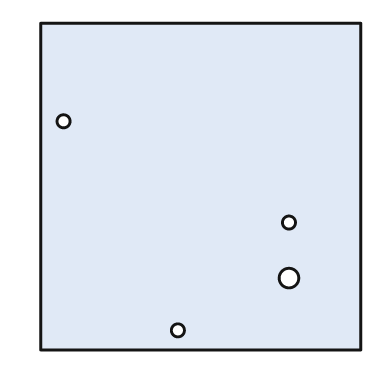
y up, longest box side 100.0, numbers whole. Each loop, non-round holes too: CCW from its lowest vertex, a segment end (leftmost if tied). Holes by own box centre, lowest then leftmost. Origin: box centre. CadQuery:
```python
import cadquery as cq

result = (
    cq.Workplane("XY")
    .moveTo(-49.0, -50.0)
    .lineTo(49.0, -50.0)
    .lineTo(49.0, 50.0)
    .lineTo(-49.0, 50.0)
    .close()
    .moveTo(-7.0, -44.0)
    .circle(2.0)
    .moveTo(27.0, -28.0)
    .circle(3.0)
    .moveTo(27.0, -11.0)
    .circle(2.0)
    .moveTo(-42.0, 20.0)
    .circle(2.0)
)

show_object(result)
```